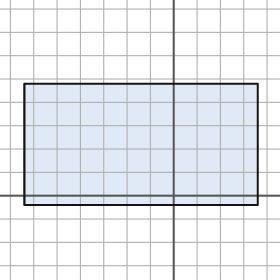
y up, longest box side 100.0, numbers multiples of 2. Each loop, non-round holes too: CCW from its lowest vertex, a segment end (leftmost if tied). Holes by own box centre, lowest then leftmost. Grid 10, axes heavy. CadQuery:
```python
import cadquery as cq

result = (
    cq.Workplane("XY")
    .moveTo(-64.0, -4.0)
    .lineTo(36.0, -4.0)
    .lineTo(36.0, 48.0)
    .lineTo(-64.0, 48.0)
    .close()
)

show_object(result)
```